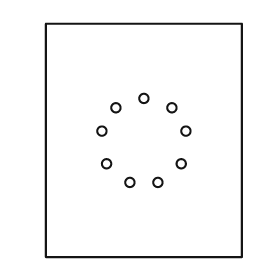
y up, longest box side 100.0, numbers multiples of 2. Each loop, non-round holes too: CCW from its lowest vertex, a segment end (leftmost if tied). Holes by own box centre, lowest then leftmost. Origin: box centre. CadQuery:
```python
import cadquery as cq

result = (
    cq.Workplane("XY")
    .moveTo(-42.0, -50.0)
    .lineTo(42.0, -50.0)
    .lineTo(42.0, 50.0)
    .lineTo(-42.0, 50.0)
    .close()
    .moveTo(-6.0, -18.0)
    .circle(2.0)
    .moveTo(6.0, -18.0)
    .circle(2.0)
    .moveTo(-16.0, -10.0)
    .circle(2.0)
    .moveTo(16.0, -10.0)
    .circle(2.0)
    .moveTo(-18.0, 4.0)
    .circle(2.0)
    .moveTo(18.0, 4.0)
    .circle(2.0)
    .moveTo(-12.0, 14.0)
    .circle(2.0)
    .moveTo(12.0, 14.0)
    .circle(2.0)
    .moveTo(0.0, 18.0)
    .circle(2.0)
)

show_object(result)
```